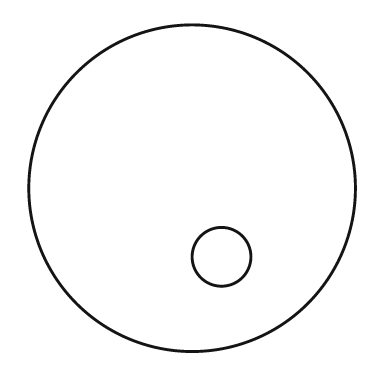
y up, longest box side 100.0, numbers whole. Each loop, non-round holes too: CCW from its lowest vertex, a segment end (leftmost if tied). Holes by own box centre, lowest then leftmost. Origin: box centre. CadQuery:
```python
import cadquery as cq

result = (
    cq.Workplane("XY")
    .moveTo(0.0, 0.0)
    .circle(50.0)
    .moveTo(9.0, -21.0)
    .circle(9.0)
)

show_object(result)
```